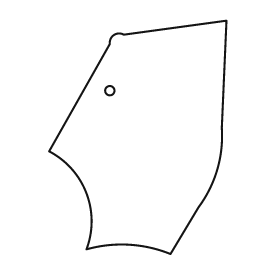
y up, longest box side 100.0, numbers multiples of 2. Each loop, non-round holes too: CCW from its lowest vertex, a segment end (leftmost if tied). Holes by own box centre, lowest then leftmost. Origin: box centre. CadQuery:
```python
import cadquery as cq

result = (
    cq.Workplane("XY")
    .moveTo(14.0, -50.0)
    .lineTo(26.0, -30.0)
    .threePointArc((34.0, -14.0), (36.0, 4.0))
    .lineTo(38.0, 50.0)
    .lineTo(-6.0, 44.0)
    .threePointArc((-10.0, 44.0), (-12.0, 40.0))
    .lineTo(-38.0, -6.0)
    .threePointArc((-22.0, -24.0), (-22.0, -48.0))
    .threePointArc((-4.0, -46.0), (14.0, -50.0))
    .close()
    .moveTo(-12.0, 20.0)
    .circle(2.0)
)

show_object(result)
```